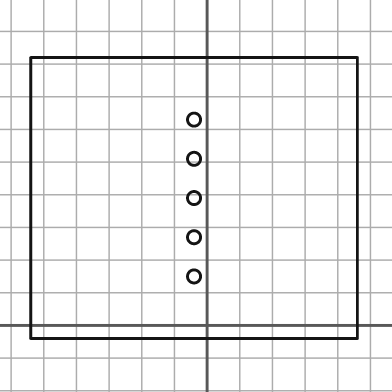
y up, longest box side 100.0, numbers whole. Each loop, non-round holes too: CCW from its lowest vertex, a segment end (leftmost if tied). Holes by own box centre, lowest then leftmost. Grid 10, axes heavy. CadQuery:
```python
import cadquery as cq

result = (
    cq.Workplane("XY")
    .moveTo(-54.0, -4.0)
    .lineTo(46.0, -4.0)
    .lineTo(46.0, 82.0)
    .lineTo(-54.0, 82.0)
    .close()
    .moveTo(-4.0, 15.0)
    .circle(2.0)
    .moveTo(-4.0, 27.0)
    .circle(2.0)
    .moveTo(-4.0, 39.0)
    .circle(2.0)
    .moveTo(-4.0, 51.0)
    .circle(2.0)
    .moveTo(-4.0, 63.0)
    .circle(2.0)
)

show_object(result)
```